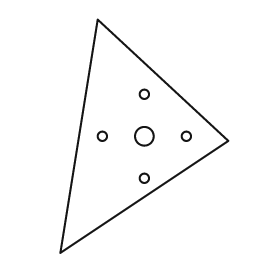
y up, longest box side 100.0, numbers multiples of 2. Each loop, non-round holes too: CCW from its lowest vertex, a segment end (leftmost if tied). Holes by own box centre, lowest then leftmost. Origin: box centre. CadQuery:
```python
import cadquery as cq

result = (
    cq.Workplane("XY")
    .moveTo(-36.0, -50.0)
    .lineTo(36.0, -2.0)
    .lineTo(-20.0, 50.0)
    .close()
    .moveTo(0.0, -18.0)
    .circle(2.0)
    .moveTo(-18.0, 0.0)
    .circle(2.0)
    .moveTo(0.0, 0.0)
    .circle(4.0)
    .moveTo(18.0, 0.0)
    .circle(2.0)
    .moveTo(0.0, 18.0)
    .circle(2.0)
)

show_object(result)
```